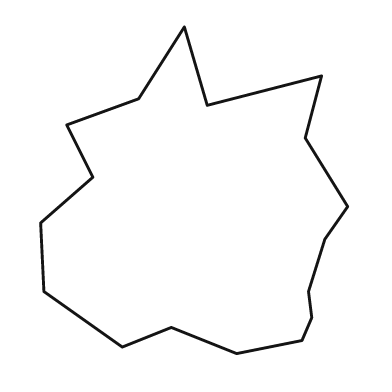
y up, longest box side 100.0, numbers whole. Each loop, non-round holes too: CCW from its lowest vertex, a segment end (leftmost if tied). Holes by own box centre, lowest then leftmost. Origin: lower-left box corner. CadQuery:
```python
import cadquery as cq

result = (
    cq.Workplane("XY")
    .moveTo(60.0, 0.0)
    .lineTo(80.0, 4.0)
    .lineTo(83.0, 11.0)
    .lineTo(82.0, 19.0)
    .lineTo(87.0, 35.0)
    .lineTo(94.0, 45.0)
    .lineTo(81.0, 66.0)
    .lineTo(86.0, 85.0)
    .lineTo(51.0, 76.0)
    .lineTo(44.0, 100.0)
    .lineTo(30.0, 78.0)
    .lineTo(8.0, 70.0)
    .lineTo(16.0, 54.0)
    .lineTo(0.0, 40.0)
    .lineTo(1.0, 19.0)
    .lineTo(25.0, 2.0)
    .lineTo(40.0, 8.0)
    .close()
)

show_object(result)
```